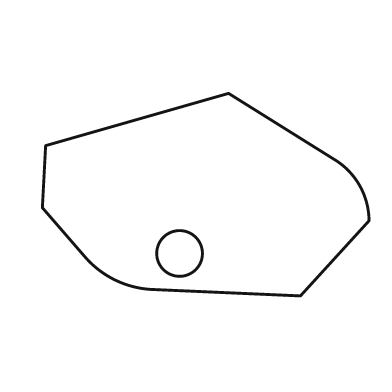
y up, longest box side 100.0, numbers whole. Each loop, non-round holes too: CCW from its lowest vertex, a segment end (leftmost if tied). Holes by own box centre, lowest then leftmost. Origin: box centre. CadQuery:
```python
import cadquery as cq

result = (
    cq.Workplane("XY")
    .moveTo(29.0, -31.0)
    .lineTo(50.0, -8.0)
    .threePointArc((47.0, 3.0), (39.0, 11.0))
    .lineTo(7.0, 31.0)
    .lineTo(-49.0, 15.0)
    .lineTo(-50.0, -4.0)
    .lineTo(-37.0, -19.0)
    .threePointArc((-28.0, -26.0), (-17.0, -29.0))
    .close()
    .moveTo(-8.0, -18.0)
    .circle(7.0)
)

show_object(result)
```